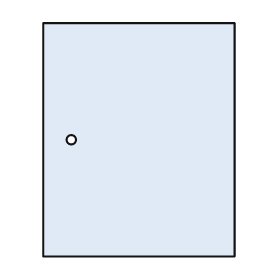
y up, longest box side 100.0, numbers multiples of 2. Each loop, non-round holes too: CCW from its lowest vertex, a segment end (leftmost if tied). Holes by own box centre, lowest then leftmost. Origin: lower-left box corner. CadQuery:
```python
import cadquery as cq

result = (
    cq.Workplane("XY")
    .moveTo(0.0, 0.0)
    .lineTo(82.0, 0.0)
    .lineTo(82.0, 100.0)
    .lineTo(0.0, 100.0)
    .close()
    .moveTo(12.0, 50.0)
    .circle(2.0)
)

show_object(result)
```